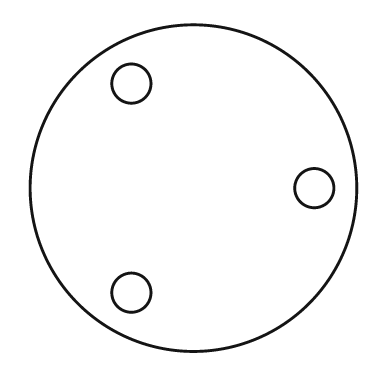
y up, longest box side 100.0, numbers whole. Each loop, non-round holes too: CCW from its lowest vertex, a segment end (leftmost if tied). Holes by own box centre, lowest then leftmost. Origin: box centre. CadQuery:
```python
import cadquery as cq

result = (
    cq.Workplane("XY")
    .moveTo(0.0, 0.0)
    .circle(50.0)
    .moveTo(-19.0, -32.0)
    .circle(6.0)
    .moveTo(37.0, 0.0)
    .circle(6.0)
    .moveTo(-19.0, 32.0)
    .circle(6.0)
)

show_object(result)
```